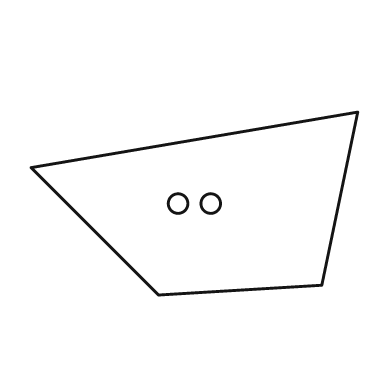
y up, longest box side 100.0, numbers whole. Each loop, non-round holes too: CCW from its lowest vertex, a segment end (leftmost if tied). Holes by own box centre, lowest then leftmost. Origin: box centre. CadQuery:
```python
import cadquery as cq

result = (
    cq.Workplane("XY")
    .moveTo(-11.0, -28.0)
    .lineTo(39.0, -25.0)
    .lineTo(50.0, 28.0)
    .lineTo(-50.0, 11.0)
    .close()
    .moveTo(-5.0, 0.0)
    .circle(3.0)
    .moveTo(5.0, 0.0)
    .circle(3.0)
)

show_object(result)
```